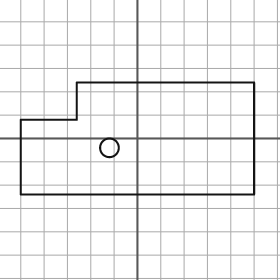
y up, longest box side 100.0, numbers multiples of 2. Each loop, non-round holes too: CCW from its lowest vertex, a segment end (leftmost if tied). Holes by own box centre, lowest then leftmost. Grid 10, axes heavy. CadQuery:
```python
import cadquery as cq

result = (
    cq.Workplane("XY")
    .moveTo(-50.0, -24.0)
    .lineTo(50.0, -24.0)
    .lineTo(50.0, 24.0)
    .lineTo(-26.0, 24.0)
    .lineTo(-26.0, 8.0)
    .lineTo(-50.0, 8.0)
    .close()
    .moveTo(-12.0, -4.0)
    .circle(4.0)
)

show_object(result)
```